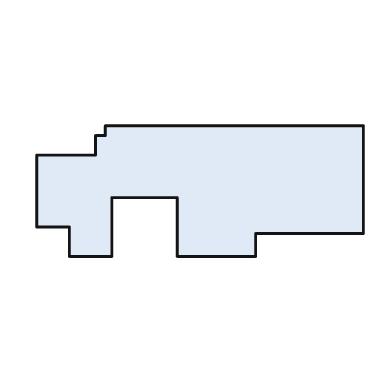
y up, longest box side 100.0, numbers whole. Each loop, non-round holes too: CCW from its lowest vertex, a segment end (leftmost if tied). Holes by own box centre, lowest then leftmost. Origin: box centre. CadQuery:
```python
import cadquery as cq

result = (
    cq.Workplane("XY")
    .moveTo(-40.0, -20.0)
    .lineTo(-27.0, -20.0)
    .lineTo(-27.0, -2.0)
    .lineTo(-7.0, -2.0)
    .lineTo(-7.0, -20.0)
    .lineTo(17.0, -20.0)
    .lineTo(17.0, -13.0)
    .lineTo(50.0, -13.0)
    .lineTo(50.0, 20.0)
    .lineTo(-29.0, 20.0)
    .lineTo(-29.0, 17.0)
    .lineTo(-32.0, 17.0)
    .lineTo(-32.0, 11.0)
    .lineTo(-50.0, 11.0)
    .lineTo(-50.0, -11.0)
    .lineTo(-40.0, -11.0)
    .close()
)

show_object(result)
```